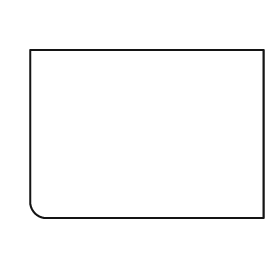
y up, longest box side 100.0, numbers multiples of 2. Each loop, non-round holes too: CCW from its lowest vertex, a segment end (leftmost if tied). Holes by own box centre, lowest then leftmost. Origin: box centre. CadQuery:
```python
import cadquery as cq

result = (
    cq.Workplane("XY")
    .moveTo(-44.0, -36.0)
    .lineTo(50.0, -36.0)
    .lineTo(50.0, 36.0)
    .lineTo(-50.0, 36.0)
    .lineTo(-50.0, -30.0)
    .threePointArc((-48.0, -34.0), (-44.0, -36.0))
    .close()
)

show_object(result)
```